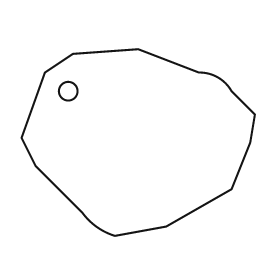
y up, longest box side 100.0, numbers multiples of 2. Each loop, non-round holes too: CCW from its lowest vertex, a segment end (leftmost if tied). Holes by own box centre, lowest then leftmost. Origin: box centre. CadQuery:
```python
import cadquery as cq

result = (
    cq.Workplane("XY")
    .moveTo(-10.0, -40.0)
    .lineTo(12.0, -36.0)
    .lineTo(40.0, -20.0)
    .lineTo(48.0, 0.0)
    .lineTo(50.0, 12.0)
    .lineTo(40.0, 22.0)
    .threePointArc((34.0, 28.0), (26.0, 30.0))
    .lineTo(0.0, 40.0)
    .lineTo(-28.0, 38.0)
    .lineTo(-40.0, 30.0)
    .lineTo(-50.0, 2.0)
    .lineTo(-44.0, -10.0)
    .lineTo(-24.0, -30.0)
    .threePointArc((-18.0, -36.0), (-10.0, -40.0))
    .close()
    .moveTo(-30.0, 22.0)
    .circle(4.0)
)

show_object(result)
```